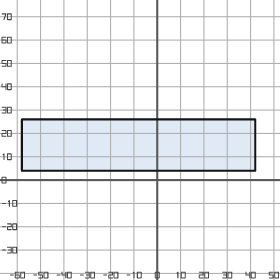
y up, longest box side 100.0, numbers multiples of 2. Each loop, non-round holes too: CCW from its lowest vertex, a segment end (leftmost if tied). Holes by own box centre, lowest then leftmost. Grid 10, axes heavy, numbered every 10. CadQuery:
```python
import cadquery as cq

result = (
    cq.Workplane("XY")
    .moveTo(-58.0, 4.0)
    .lineTo(42.0, 4.0)
    .lineTo(42.0, 26.0)
    .lineTo(-58.0, 26.0)
    .close()
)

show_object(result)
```